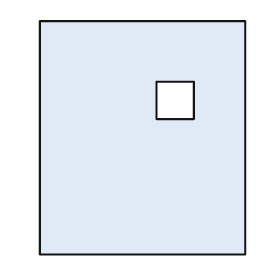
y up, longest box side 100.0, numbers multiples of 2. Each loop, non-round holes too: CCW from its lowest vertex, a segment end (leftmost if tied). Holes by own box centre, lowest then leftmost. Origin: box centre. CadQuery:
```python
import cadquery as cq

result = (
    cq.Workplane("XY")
    .moveTo(-44.0, -50.0)
    .lineTo(44.0, -50.0)
    .lineTo(44.0, 50.0)
    .lineTo(-44.0, 50.0)
    .close()
    .moveTo(6.0, 8.0)
    .lineTo(22.0, 8.0)
    .lineTo(22.0, 24.0)
    .lineTo(6.0, 24.0)
    .close()
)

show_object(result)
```